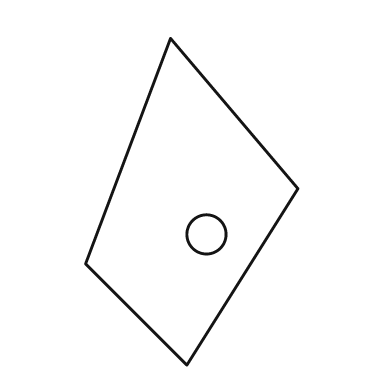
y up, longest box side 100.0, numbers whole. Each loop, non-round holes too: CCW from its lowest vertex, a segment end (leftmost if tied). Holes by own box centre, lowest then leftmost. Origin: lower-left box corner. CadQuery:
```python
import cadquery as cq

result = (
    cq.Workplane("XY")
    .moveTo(31.0, 0.0)
    .lineTo(65.0, 54.0)
    .lineTo(26.0, 100.0)
    .lineTo(0.0, 31.0)
    .close()
    .moveTo(37.0, 40.0)
    .circle(6.0)
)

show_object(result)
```